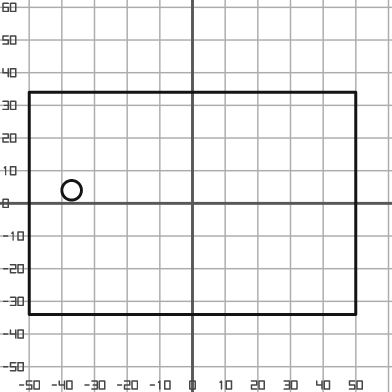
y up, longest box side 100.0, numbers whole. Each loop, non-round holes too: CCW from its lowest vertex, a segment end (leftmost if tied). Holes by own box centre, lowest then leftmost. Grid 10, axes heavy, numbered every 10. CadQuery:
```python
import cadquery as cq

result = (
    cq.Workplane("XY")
    .moveTo(-50.0, -34.0)
    .lineTo(50.0, -34.0)
    .lineTo(50.0, 34.0)
    .lineTo(-50.0, 34.0)
    .close()
    .moveTo(-37.0, 4.0)
    .circle(3.0)
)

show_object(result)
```